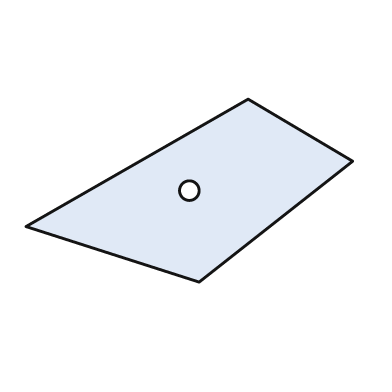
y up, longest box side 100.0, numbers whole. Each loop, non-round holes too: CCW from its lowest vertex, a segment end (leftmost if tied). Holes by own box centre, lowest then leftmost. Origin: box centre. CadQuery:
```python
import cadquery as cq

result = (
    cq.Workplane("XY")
    .moveTo(3.0, -28.0)
    .lineTo(50.0, 9.0)
    .lineTo(18.0, 28.0)
    .lineTo(-50.0, -11.0)
    .close()
    .moveTo(0.0, 0.0)
    .circle(3.0)
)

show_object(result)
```